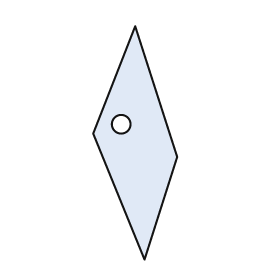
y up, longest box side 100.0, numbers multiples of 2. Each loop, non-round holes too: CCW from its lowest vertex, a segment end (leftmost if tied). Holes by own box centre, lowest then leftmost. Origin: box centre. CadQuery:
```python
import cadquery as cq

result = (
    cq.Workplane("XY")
    .moveTo(4.0, -50.0)
    .lineTo(18.0, -6.0)
    .lineTo(0.0, 50.0)
    .lineTo(-18.0, 4.0)
    .close()
    .moveTo(-6.0, 8.0)
    .circle(4.0)
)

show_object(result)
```